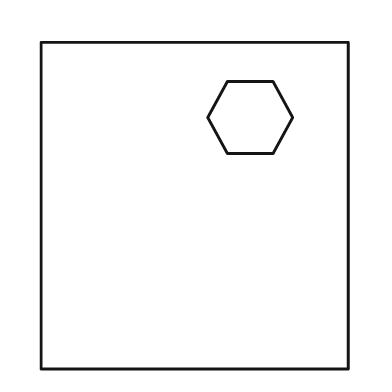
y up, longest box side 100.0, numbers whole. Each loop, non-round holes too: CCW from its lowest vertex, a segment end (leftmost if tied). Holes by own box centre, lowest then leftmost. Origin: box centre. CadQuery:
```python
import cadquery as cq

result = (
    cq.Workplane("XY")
    .moveTo(-47.0, -50.0)
    .lineTo(47.0, -50.0)
    .lineTo(47.0, 50.0)
    .lineTo(-47.0, 50.0)
    .close()
    .moveTo(10.0, 16.0)
    .lineTo(24.0, 16.0)
    .lineTo(30.0, 27.0)
    .lineTo(24.0, 38.0)
    .lineTo(10.0, 38.0)
    .lineTo(4.0, 27.0)
    .close()
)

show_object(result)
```